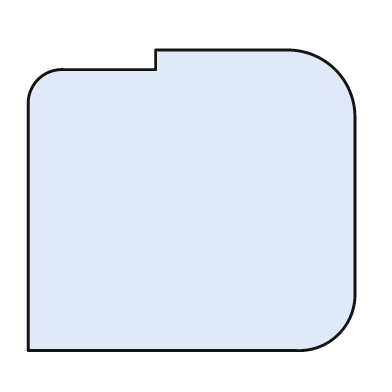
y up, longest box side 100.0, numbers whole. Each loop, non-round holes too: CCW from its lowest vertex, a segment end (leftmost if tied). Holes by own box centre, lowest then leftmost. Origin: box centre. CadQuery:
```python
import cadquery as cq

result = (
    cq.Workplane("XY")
    .moveTo(-50.0, -46.0)
    .lineTo(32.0, -46.0)
    .threePointArc((45.0, -41.0), (50.0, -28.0))
    .lineTo(50.0, 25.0)
    .threePointArc((44.0, 40.0), (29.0, 46.0))
    .lineTo(-11.0, 46.0)
    .lineTo(-11.0, 40.0)
    .lineTo(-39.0, 40.0)
    .threePointArc((-47.0, 37.0), (-50.0, 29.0))
    .close()
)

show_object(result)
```